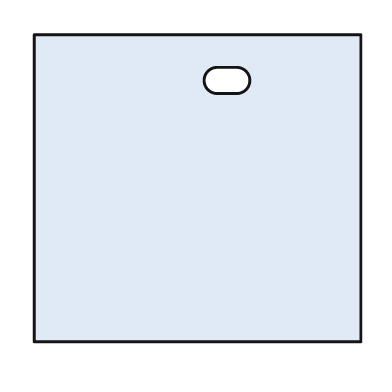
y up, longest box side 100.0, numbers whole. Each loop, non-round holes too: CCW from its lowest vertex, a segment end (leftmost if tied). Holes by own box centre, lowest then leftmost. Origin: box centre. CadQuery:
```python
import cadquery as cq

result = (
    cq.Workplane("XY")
    .moveTo(-50.0, -47.0)
    .lineTo(50.0, -47.0)
    .lineTo(50.0, 47.0)
    .lineTo(-50.0, 47.0)
    .close()
    .moveTo(6.0, 29.0)
    .lineTo(12.0, 29.0)
    .threePointArc((16.0, 33.0), (12.0, 37.0))
    .lineTo(6.0, 37.0)
    .threePointArc((2.0, 33.0), (6.0, 29.0))
    .close()
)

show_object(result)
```